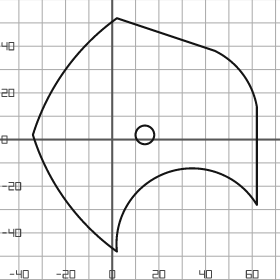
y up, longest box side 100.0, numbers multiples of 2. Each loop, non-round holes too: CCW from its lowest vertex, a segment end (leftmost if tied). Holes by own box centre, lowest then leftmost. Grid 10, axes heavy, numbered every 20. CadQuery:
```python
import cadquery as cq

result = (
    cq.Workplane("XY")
    .moveTo(2.0, -48.0)
    .threePointArc((24.0, -14.0), (62.0, -28.0))
    .lineTo(62.0, 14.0)
    .threePointArc((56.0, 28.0), (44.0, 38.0))
    .lineTo(2.0, 52.0)
    .threePointArc((-20.0, 30.0), (-34.0, 2.0))
    .threePointArc((-20.0, -26.0), (2.0, -48.0))
    .close()
    .moveTo(14.0, 2.0)
    .circle(4.0)
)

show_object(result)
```